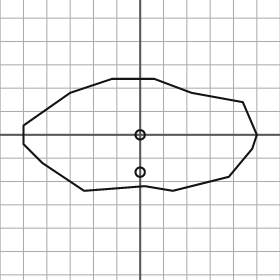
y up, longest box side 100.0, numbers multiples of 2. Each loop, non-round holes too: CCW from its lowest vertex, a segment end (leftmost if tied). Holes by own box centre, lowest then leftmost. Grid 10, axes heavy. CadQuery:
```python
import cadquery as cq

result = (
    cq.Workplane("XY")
    .moveTo(-24.0, -24.0)
    .lineTo(2.0, -22.0)
    .lineTo(14.0, -24.0)
    .lineTo(38.0, -18.0)
    .lineTo(48.0, -6.0)
    .lineTo(50.0, 0.0)
    .lineTo(44.0, 14.0)
    .lineTo(22.0, 18.0)
    .lineTo(6.0, 24.0)
    .lineTo(-12.0, 24.0)
    .lineTo(-30.0, 18.0)
    .lineTo(-50.0, 4.0)
    .lineTo(-50.0, -4.0)
    .lineTo(-42.0, -12.0)
    .close()
    .moveTo(0.0, -16.0)
    .circle(2.0)
    .moveTo(0.0, 0.0)
    .circle(2.0)
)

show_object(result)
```